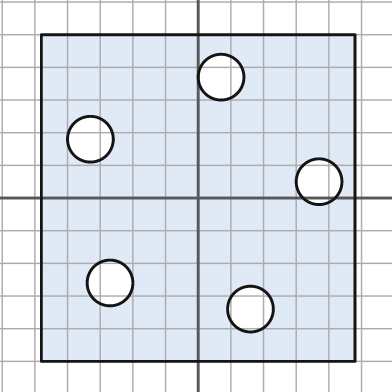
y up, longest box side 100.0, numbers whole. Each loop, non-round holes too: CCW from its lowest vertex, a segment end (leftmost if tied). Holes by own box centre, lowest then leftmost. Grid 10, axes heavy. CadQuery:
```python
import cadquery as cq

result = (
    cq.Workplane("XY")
    .moveTo(-48.0, -50.0)
    .lineTo(48.0, -50.0)
    .lineTo(48.0, 50.0)
    .lineTo(-48.0, 50.0)
    .close()
    .moveTo(16.0, -34.0)
    .circle(7.0)
    .moveTo(-27.0, -26.0)
    .circle(7.0)
    .moveTo(37.0, 5.0)
    .circle(7.0)
    .moveTo(-33.0, 18.0)
    .circle(7.0)
    .moveTo(7.0, 37.0)
    .circle(7.0)
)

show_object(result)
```